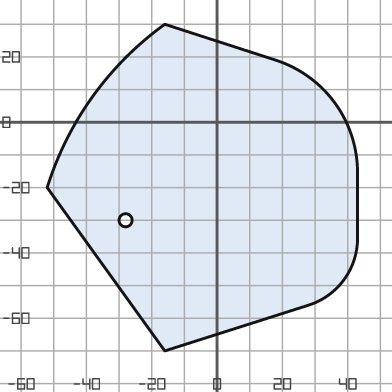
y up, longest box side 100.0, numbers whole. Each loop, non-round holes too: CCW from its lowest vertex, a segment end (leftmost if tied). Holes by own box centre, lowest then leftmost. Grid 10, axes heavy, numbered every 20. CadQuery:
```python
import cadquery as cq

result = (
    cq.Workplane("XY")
    .moveTo(-16.0, -70.0)
    .lineTo(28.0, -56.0)
    .threePointArc((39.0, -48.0), (43.0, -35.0))
    .lineTo(43.0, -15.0)
    .threePointArc((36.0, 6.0), (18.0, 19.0))
    .lineTo(-16.0, 30.0)
    .threePointArc((-38.0, 8.0), (-52.0, -20.0))
    .close()
    .moveTo(-28.0, -30.0)
    .circle(2.0)
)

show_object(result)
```